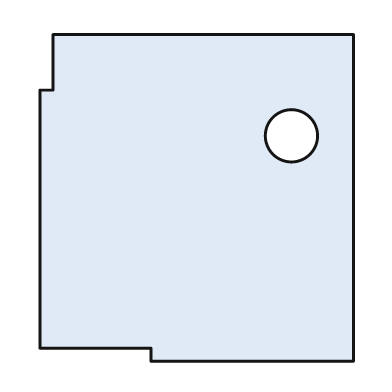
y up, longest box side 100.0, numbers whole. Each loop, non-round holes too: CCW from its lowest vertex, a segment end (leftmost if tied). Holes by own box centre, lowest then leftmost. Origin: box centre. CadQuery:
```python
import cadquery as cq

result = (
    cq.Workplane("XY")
    .moveTo(-14.0, -50.0)
    .lineTo(48.0, -50.0)
    .lineTo(48.0, 50.0)
    .lineTo(-44.0, 50.0)
    .lineTo(-44.0, 33.0)
    .lineTo(-48.0, 33.0)
    .lineTo(-48.0, -46.0)
    .lineTo(-14.0, -46.0)
    .close()
    .moveTo(29.0, 19.0)
    .circle(8.0)
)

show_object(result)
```